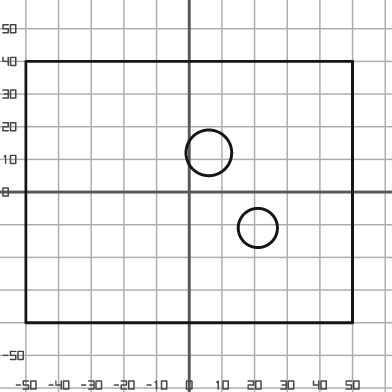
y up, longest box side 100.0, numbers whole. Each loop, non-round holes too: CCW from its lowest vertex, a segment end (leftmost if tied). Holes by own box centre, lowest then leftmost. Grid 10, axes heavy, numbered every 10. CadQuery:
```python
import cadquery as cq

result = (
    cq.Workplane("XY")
    .moveTo(-50.0, -40.0)
    .lineTo(50.0, -40.0)
    .lineTo(50.0, 40.0)
    .lineTo(-50.0, 40.0)
    .close()
    .moveTo(21.0, -11.0)
    .circle(6.0)
    .moveTo(6.0, 12.0)
    .circle(7.0)
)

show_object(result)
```